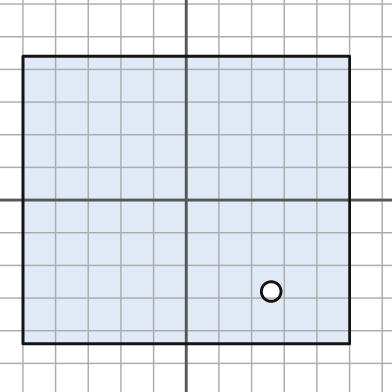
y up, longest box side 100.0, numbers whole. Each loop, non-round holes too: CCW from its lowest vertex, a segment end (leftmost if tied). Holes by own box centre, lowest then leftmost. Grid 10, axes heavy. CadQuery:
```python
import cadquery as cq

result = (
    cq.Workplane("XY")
    .moveTo(-50.0, -44.0)
    .lineTo(50.0, -44.0)
    .lineTo(50.0, 44.0)
    .lineTo(-50.0, 44.0)
    .close()
    .moveTo(26.0, -28.0)
    .circle(3.0)
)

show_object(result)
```